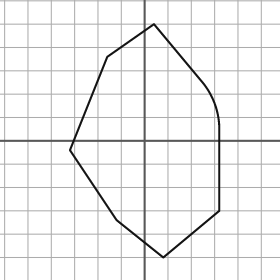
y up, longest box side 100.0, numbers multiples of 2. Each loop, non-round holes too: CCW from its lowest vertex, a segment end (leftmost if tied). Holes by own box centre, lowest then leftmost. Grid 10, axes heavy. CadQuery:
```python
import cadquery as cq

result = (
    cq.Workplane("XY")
    .moveTo(8.0, -50.0)
    .lineTo(32.0, -30.0)
    .lineTo(32.0, 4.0)
    .threePointArc((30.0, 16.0), (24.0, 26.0))
    .lineTo(4.0, 50.0)
    .lineTo(-16.0, 36.0)
    .lineTo(-32.0, -4.0)
    .lineTo(-12.0, -34.0)
    .close()
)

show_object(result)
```